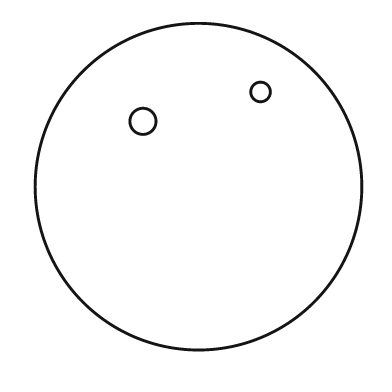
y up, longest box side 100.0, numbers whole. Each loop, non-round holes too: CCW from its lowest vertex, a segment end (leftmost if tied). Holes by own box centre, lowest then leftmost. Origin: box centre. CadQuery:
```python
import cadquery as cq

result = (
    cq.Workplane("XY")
    .moveTo(0.0, 0.0)
    .circle(50.0)
    .moveTo(-17.0, 20.0)
    .circle(4.0)
    .moveTo(19.0, 29.0)
    .circle(3.0)
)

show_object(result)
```